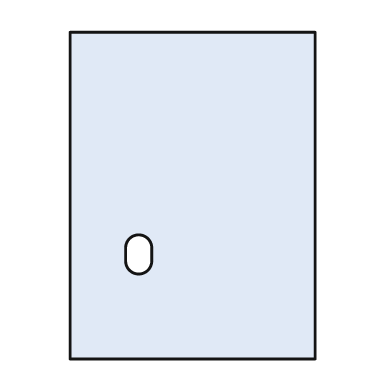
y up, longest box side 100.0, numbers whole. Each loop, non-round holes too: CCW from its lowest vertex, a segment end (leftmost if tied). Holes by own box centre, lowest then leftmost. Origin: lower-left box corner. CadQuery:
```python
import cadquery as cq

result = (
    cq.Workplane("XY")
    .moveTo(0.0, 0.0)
    .lineTo(75.0, 0.0)
    .lineTo(75.0, 100.0)
    .lineTo(0.0, 100.0)
    .close()
    .moveTo(17.0, 30.0)
    .threePointArc((21.0, 26.0), (25.0, 30.0))
    .lineTo(25.0, 34.0)
    .threePointArc((21.0, 38.0), (17.0, 34.0))
    .close()
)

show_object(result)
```